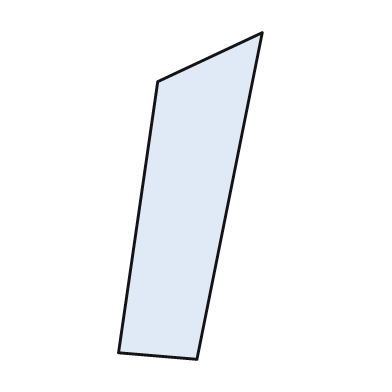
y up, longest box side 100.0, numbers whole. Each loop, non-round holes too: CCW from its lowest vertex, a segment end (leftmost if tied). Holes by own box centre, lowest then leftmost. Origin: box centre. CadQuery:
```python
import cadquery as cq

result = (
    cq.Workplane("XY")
    .moveTo(2.0, -50.0)
    .lineTo(22.0, 50.0)
    .lineTo(-10.0, 35.0)
    .lineTo(-22.0, -48.0)
    .close()
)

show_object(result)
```